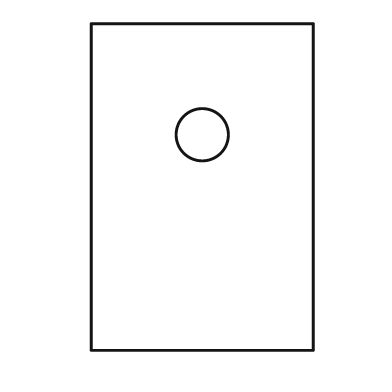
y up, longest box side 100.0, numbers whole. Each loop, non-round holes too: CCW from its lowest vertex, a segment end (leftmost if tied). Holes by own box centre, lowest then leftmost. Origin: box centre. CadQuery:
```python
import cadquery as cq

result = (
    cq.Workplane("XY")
    .moveTo(-34.0, -50.0)
    .lineTo(34.0, -50.0)
    .lineTo(34.0, 50.0)
    .lineTo(-34.0, 50.0)
    .close()
    .moveTo(0.0, 16.0)
    .circle(8.0)
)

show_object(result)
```